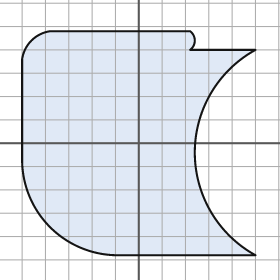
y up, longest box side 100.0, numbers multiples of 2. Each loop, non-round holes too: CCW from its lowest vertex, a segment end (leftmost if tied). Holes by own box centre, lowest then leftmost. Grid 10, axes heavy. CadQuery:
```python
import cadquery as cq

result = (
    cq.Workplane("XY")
    .moveTo(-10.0, -48.0)
    .lineTo(50.0, -48.0)
    .threePointArc((24.0, -4.0), (50.0, 40.0))
    .lineTo(22.0, 40.0)
    .threePointArc((24.0, 44.0), (22.0, 48.0))
    .lineTo(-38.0, 48.0)
    .threePointArc((-46.0, 44.0), (-50.0, 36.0))
    .lineTo(-50.0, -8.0)
    .threePointArc((-38.0, -36.0), (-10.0, -48.0))
    .close()
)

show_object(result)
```